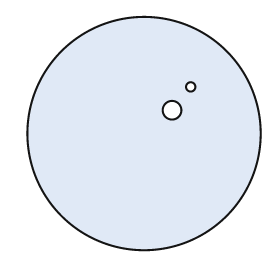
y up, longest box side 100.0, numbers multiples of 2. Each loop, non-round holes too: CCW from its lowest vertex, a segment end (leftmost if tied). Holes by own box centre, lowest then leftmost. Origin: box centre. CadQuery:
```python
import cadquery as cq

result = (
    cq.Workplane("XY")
    .moveTo(0.0, 0.0)
    .circle(50.0)
    .moveTo(12.0, 10.0)
    .circle(4.0)
    .moveTo(20.0, 20.0)
    .circle(2.0)
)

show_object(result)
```